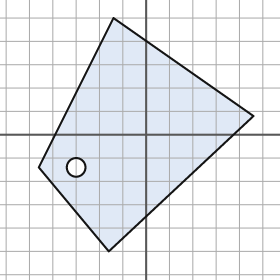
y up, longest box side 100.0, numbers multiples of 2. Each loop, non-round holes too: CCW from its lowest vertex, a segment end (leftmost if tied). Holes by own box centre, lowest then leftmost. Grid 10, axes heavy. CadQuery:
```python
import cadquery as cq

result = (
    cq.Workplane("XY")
    .moveTo(-16.0, -50.0)
    .lineTo(46.0, 8.0)
    .lineTo(-14.0, 50.0)
    .lineTo(-46.0, -14.0)
    .close()
    .moveTo(-30.0, -14.0)
    .circle(4.0)
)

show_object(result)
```